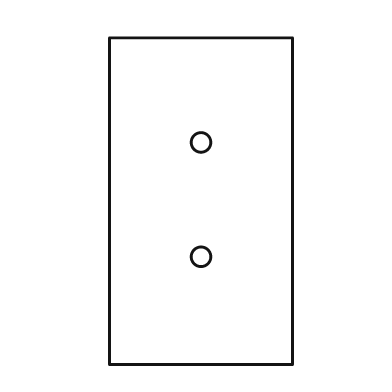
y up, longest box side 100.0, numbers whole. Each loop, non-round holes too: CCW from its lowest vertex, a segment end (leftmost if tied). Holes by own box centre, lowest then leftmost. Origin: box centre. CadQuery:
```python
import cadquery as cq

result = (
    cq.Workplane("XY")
    .moveTo(-28.0, -50.0)
    .lineTo(28.0, -50.0)
    .lineTo(28.0, 50.0)
    .lineTo(-28.0, 50.0)
    .close()
    .moveTo(0.0, -17.0)
    .circle(3.0)
    .moveTo(0.0, 18.0)
    .circle(3.0)
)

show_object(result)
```